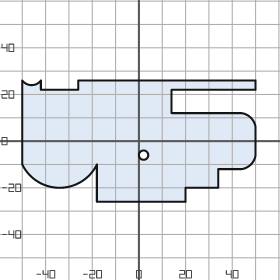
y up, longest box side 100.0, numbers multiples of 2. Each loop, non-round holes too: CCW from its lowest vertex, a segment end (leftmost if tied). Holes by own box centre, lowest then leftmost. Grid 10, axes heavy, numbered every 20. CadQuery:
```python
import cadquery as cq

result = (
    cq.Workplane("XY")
    .moveTo(-18.0, -26.0)
    .lineTo(20.0, -26.0)
    .lineTo(20.0, -20.0)
    .lineTo(34.0, -20.0)
    .lineTo(34.0, -12.0)
    .lineTo(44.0, -12.0)
    .threePointArc((48.0, -10.0), (50.0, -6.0))
    .lineTo(50.0, 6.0)
    .threePointArc((48.0, 10.0), (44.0, 12.0))
    .lineTo(14.0, 12.0)
    .lineTo(14.0, 22.0)
    .lineTo(50.0, 22.0)
    .lineTo(50.0, 26.0)
    .lineTo(-26.0, 26.0)
    .lineTo(-26.0, 22.0)
    .lineTo(-42.0, 22.0)
    .lineTo(-42.0, 26.0)
    .threePointArc((-46.0, 24.0), (-50.0, 26.0))
    .lineTo(-50.0, -10.0)
    .threePointArc((-34.0, -20.0), (-18.0, -10.0))
    .close()
    .moveTo(2.0, -6.0)
    .circle(2.0)
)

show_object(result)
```